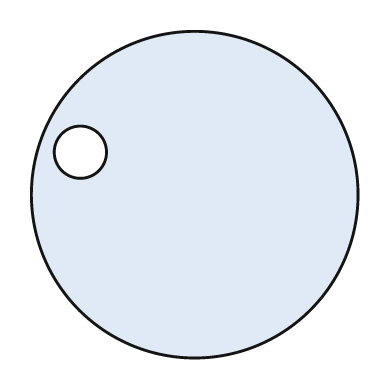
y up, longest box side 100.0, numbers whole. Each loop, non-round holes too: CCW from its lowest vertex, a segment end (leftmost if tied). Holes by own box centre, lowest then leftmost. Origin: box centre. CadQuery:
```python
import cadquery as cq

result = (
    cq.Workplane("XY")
    .moveTo(0.0, 0.0)
    .circle(50.0)
    .moveTo(-35.0, 13.0)
    .circle(8.0)
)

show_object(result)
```